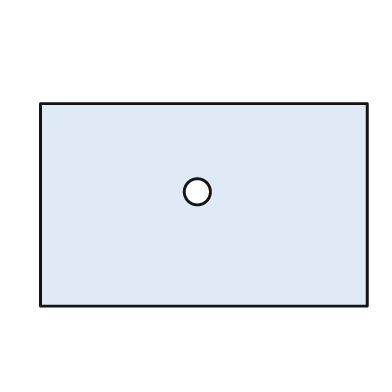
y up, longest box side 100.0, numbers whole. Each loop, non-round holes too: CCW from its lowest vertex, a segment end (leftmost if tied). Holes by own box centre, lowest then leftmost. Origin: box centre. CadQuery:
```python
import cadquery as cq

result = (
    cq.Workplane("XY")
    .moveTo(-50.0, -31.0)
    .lineTo(50.0, -31.0)
    .lineTo(50.0, 31.0)
    .lineTo(-50.0, 31.0)
    .close()
    .moveTo(-2.0, 4.0)
    .circle(4.0)
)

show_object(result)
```